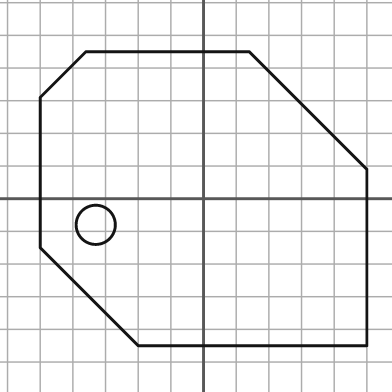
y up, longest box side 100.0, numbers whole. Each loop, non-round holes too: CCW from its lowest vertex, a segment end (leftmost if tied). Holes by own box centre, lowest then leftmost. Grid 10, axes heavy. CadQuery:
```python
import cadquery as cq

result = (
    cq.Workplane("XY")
    .moveTo(-20.0, -45.0)
    .lineTo(50.0, -45.0)
    .lineTo(50.0, 9.0)
    .lineTo(14.0, 45.0)
    .lineTo(-36.0, 45.0)
    .lineTo(-50.0, 31.0)
    .lineTo(-50.0, -15.0)
    .close()
    .moveTo(-33.0, -8.0)
    .circle(6.0)
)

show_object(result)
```